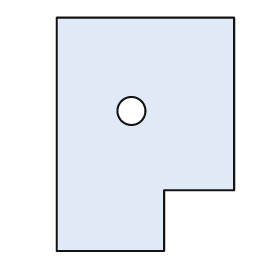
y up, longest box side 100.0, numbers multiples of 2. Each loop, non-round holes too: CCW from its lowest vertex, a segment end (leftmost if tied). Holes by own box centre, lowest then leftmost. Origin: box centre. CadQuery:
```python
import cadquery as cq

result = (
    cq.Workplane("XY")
    .moveTo(-38.0, -50.0)
    .lineTo(8.0, -50.0)
    .lineTo(8.0, -24.0)
    .lineTo(38.0, -24.0)
    .lineTo(38.0, 50.0)
    .lineTo(-38.0, 50.0)
    .close()
    .moveTo(-6.0, 10.0)
    .circle(6.0)
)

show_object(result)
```